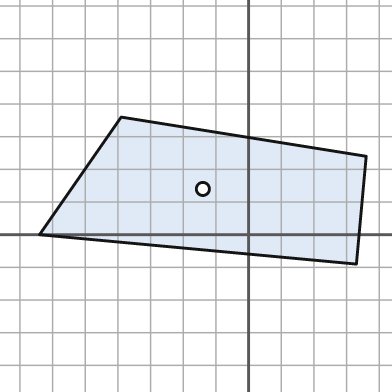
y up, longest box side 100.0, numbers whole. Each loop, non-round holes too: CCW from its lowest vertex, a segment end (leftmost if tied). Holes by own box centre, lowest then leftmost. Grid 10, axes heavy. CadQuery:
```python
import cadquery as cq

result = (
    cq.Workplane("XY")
    .moveTo(33.0, -9.0)
    .lineTo(36.0, 24.0)
    .lineTo(-39.0, 36.0)
    .lineTo(-64.0, 0.0)
    .close()
    .moveTo(-14.0, 14.0)
    .circle(2.0)
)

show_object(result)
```